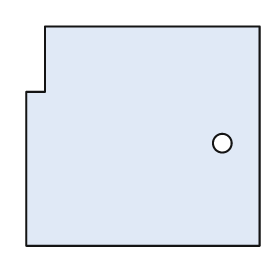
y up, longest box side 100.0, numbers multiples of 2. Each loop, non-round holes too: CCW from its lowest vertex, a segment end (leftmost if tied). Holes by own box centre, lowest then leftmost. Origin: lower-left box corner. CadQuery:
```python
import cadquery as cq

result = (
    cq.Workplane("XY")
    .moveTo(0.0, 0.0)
    .lineTo(100.0, 0.0)
    .lineTo(100.0, 94.0)
    .lineTo(8.0, 94.0)
    .lineTo(8.0, 66.0)
    .lineTo(0.0, 66.0)
    .close()
    .moveTo(84.0, 44.0)
    .circle(4.0)
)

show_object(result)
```